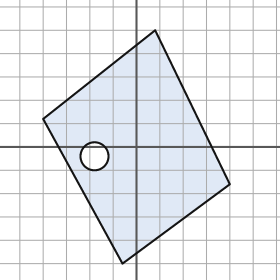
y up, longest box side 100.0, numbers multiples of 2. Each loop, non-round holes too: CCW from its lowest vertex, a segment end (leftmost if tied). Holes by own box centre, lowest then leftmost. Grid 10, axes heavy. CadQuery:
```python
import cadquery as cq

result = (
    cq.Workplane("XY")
    .moveTo(-6.0, -50.0)
    .lineTo(40.0, -16.0)
    .lineTo(8.0, 50.0)
    .lineTo(-40.0, 12.0)
    .close()
    .moveTo(-18.0, -4.0)
    .circle(6.0)
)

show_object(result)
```